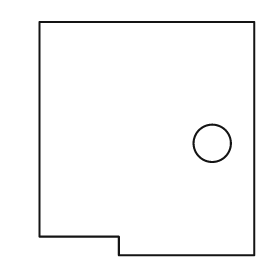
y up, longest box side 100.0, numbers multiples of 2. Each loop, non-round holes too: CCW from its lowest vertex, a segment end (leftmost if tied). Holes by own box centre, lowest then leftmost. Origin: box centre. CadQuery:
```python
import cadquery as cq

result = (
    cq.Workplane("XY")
    .moveTo(-12.0, -50.0)
    .lineTo(46.0, -50.0)
    .lineTo(46.0, 50.0)
    .lineTo(-46.0, 50.0)
    .lineTo(-46.0, -42.0)
    .lineTo(-12.0, -42.0)
    .close()
    .moveTo(28.0, -2.0)
    .circle(8.0)
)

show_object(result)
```